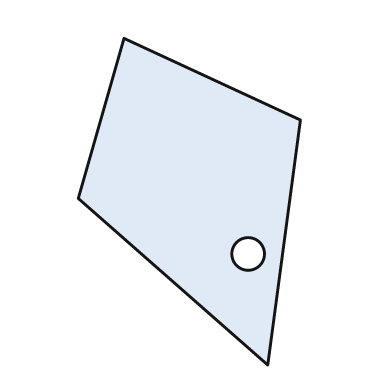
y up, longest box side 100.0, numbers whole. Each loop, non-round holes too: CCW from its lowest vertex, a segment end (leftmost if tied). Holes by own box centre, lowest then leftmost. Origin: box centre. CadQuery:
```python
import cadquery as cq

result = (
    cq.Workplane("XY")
    .moveTo(24.0, -50.0)
    .lineTo(34.0, 25.0)
    .lineTo(-20.0, 50.0)
    .lineTo(-34.0, 1.0)
    .close()
    .moveTo(18.0, -16.0)
    .circle(5.0)
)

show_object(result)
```